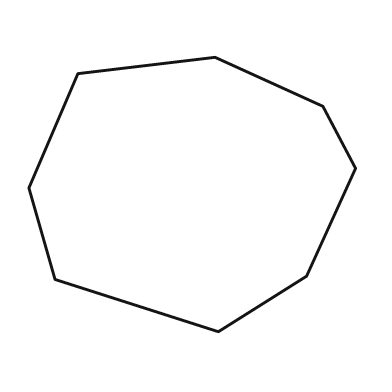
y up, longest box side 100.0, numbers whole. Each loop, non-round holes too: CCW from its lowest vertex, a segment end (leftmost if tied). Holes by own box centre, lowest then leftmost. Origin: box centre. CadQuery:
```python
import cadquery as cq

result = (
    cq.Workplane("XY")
    .moveTo(8.0, -42.0)
    .lineTo(35.0, -25.0)
    .lineTo(50.0, 8.0)
    .lineTo(40.0, 27.0)
    .lineTo(7.0, 42.0)
    .lineTo(-35.0, 37.0)
    .lineTo(-50.0, 2.0)
    .lineTo(-42.0, -26.0)
    .close()
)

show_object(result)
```